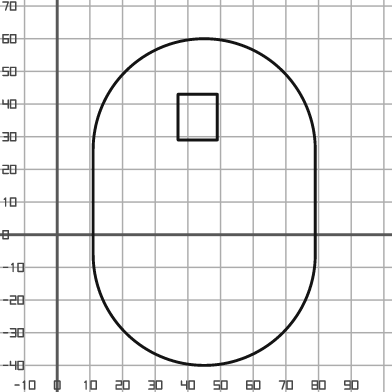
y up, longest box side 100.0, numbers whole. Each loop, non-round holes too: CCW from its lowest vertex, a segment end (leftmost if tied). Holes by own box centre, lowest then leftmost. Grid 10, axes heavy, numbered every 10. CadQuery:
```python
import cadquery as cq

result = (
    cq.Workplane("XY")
    .moveTo(11.0, -6.0)
    .threePointArc((45.0, -40.0), (79.0, -6.0))
    .lineTo(79.0, 26.0)
    .threePointArc((45.0, 60.0), (11.0, 26.0))
    .close()
    .moveTo(37.0, 29.0)
    .lineTo(49.0, 29.0)
    .lineTo(49.0, 43.0)
    .lineTo(37.0, 43.0)
    .close()
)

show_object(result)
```